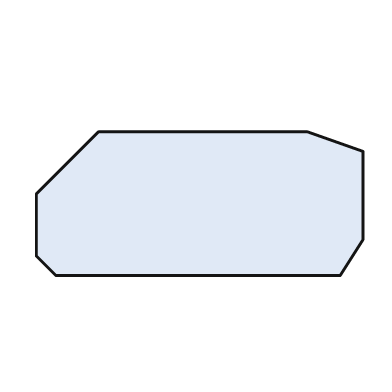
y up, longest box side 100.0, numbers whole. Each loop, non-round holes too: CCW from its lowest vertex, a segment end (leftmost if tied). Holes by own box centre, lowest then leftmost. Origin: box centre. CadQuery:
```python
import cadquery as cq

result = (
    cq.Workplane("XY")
    .moveTo(-44.0, -22.0)
    .lineTo(43.0, -22.0)
    .lineTo(50.0, -11.0)
    .lineTo(50.0, 16.0)
    .lineTo(33.0, 22.0)
    .lineTo(-31.0, 22.0)
    .lineTo(-50.0, 3.0)
    .lineTo(-50.0, -16.0)
    .close()
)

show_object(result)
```